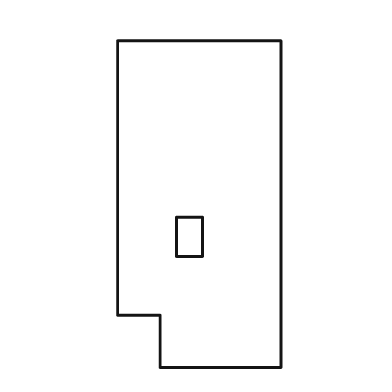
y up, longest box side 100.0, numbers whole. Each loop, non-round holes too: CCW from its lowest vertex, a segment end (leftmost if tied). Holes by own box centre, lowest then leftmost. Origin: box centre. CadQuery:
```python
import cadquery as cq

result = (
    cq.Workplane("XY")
    .moveTo(-12.0, -50.0)
    .lineTo(25.0, -50.0)
    .lineTo(25.0, 50.0)
    .lineTo(-25.0, 50.0)
    .lineTo(-25.0, -34.0)
    .lineTo(-12.0, -34.0)
    .close()
    .moveTo(-7.0, -16.0)
    .lineTo(1.0, -16.0)
    .lineTo(1.0, -4.0)
    .lineTo(-7.0, -4.0)
    .close()
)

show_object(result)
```